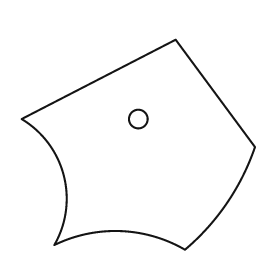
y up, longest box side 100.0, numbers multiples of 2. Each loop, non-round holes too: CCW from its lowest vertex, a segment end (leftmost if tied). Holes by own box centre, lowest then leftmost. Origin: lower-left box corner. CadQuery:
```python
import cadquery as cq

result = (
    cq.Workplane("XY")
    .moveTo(70.0, 0.0)
    .threePointArc((88.0, 20.0), (100.0, 44.0))
    .lineTo(66.0, 90.0)
    .lineTo(0.0, 56.0)
    .threePointArc((18.0, 32.0), (14.0, 2.0))
    .threePointArc((42.0, 8.0), (70.0, 0.0))
    .close()
    .moveTo(50.0, 56.0)
    .circle(4.0)
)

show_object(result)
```